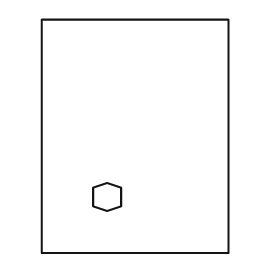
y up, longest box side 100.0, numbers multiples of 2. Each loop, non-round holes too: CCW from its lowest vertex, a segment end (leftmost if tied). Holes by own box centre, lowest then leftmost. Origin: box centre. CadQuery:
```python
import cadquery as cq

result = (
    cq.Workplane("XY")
    .moveTo(-40.0, -50.0)
    .lineTo(40.0, -50.0)
    .lineTo(40.0, 50.0)
    .lineTo(-40.0, 50.0)
    .close()
    .moveTo(-12.0, -32.0)
    .lineTo(-6.0, -30.0)
    .lineTo(-6.0, -22.0)
    .lineTo(-12.0, -20.0)
    .lineTo(-18.0, -22.0)
    .lineTo(-18.0, -30.0)
    .close()
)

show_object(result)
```